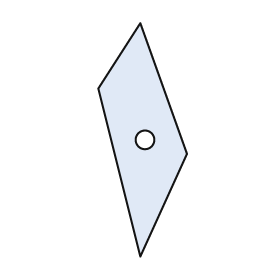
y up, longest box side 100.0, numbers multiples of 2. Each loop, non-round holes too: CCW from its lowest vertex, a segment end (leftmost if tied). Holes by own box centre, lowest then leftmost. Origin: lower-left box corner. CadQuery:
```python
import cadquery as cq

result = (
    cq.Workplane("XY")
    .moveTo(18.0, 0.0)
    .lineTo(38.0, 44.0)
    .lineTo(18.0, 100.0)
    .lineTo(0.0, 72.0)
    .close()
    .moveTo(20.0, 50.0)
    .circle(4.0)
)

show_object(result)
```